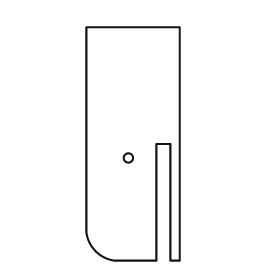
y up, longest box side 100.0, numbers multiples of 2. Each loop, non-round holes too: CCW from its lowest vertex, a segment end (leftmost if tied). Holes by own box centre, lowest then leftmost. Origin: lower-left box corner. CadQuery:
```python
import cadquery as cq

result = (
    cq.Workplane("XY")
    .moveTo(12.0, 0.0)
    .lineTo(30.0, 0.0)
    .lineTo(30.0, 50.0)
    .lineTo(36.0, 50.0)
    .lineTo(36.0, 0.0)
    .lineTo(40.0, 0.0)
    .lineTo(40.0, 100.0)
    .lineTo(0.0, 100.0)
    .lineTo(0.0, 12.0)
    .threePointArc((4.0, 4.0), (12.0, 0.0))
    .close()
    .moveTo(18.0, 44.0)
    .circle(2.0)
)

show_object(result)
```